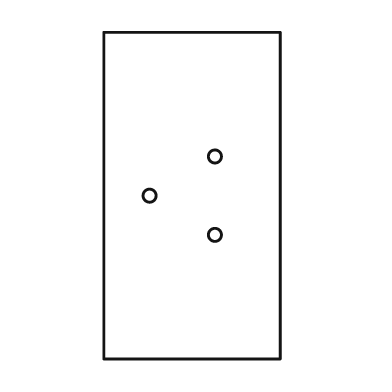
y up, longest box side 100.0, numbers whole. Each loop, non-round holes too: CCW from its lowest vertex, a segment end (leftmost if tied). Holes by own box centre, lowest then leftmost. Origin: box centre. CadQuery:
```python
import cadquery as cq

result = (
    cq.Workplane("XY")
    .moveTo(-27.0, -50.0)
    .lineTo(27.0, -50.0)
    .lineTo(27.0, 50.0)
    .lineTo(-27.0, 50.0)
    .close()
    .moveTo(7.0, -12.0)
    .circle(2.0)
    .moveTo(-13.0, 0.0)
    .circle(2.0)
    .moveTo(7.0, 12.0)
    .circle(2.0)
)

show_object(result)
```